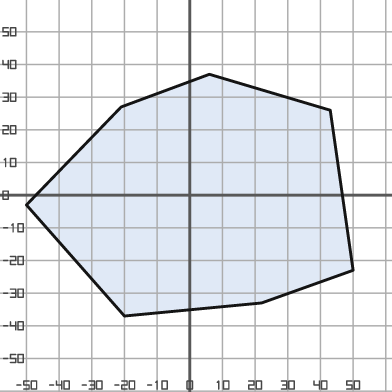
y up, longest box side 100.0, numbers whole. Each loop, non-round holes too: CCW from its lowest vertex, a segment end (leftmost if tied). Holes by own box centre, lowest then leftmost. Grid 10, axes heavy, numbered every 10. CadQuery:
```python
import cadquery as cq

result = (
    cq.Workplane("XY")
    .moveTo(-20.0, -37.0)
    .lineTo(22.0, -33.0)
    .lineTo(50.0, -23.0)
    .lineTo(43.0, 26.0)
    .lineTo(6.0, 37.0)
    .lineTo(-21.0, 27.0)
    .lineTo(-50.0, -3.0)
    .close()
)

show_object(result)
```